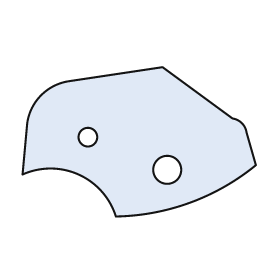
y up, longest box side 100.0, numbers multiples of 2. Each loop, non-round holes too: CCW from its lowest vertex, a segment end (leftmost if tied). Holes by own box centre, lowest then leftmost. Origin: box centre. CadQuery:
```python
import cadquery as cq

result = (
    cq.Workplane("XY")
    .moveTo(-10.0, -32.0)
    .threePointArc((22.0, -26.0), (50.0, -10.0))
    .lineTo(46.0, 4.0)
    .threePointArc((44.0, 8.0), (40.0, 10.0))
    .lineTo(10.0, 32.0)
    .lineTo(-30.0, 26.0)
    .threePointArc((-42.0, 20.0), (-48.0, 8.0))
    .lineTo(-50.0, -14.0)
    .threePointArc((-26.0, -14.0), (-10.0, -32.0))
    .close()
    .moveTo(12.0, -12.0)
    .circle(6.0)
    .moveTo(-22.0, 2.0)
    .circle(4.0)
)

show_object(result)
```